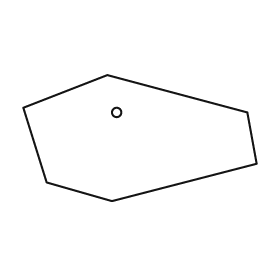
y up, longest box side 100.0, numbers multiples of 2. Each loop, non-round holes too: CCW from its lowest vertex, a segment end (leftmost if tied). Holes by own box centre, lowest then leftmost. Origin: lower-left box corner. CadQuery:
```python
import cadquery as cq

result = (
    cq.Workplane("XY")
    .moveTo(38.0, 0.0)
    .lineTo(100.0, 16.0)
    .lineTo(96.0, 38.0)
    .lineTo(36.0, 54.0)
    .lineTo(0.0, 40.0)
    .lineTo(10.0, 8.0)
    .close()
    .moveTo(40.0, 38.0)
    .circle(2.0)
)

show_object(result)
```